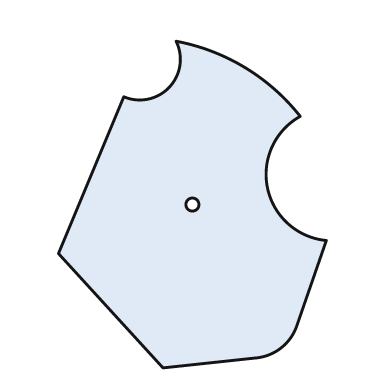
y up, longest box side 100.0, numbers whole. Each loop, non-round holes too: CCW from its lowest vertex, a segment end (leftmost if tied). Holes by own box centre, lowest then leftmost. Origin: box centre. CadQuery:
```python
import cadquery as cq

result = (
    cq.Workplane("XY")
    .moveTo(-9.0, -50.0)
    .lineTo(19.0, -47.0)
    .threePointArc((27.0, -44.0), (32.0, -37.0))
    .lineTo(41.0, -11.0)
    .threePointArc((23.0, 5.0), (33.0, 27.0))
    .threePointArc((16.0, 42.0), (-5.0, 50.0))
    .threePointArc((-7.0, 36.0), (-21.0, 33.0))
    .lineTo(-41.0, -15.0)
    .close()
    .moveTo(0.0, 0.0)
    .circle(2.0)
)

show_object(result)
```